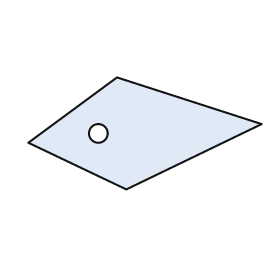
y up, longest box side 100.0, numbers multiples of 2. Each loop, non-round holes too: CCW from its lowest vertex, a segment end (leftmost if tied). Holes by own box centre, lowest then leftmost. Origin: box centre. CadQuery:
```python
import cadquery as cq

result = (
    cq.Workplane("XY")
    .moveTo(-8.0, -24.0)
    .lineTo(50.0, 4.0)
    .lineTo(-12.0, 24.0)
    .lineTo(-50.0, -4.0)
    .close()
    .moveTo(-20.0, 0.0)
    .circle(4.0)
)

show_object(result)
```